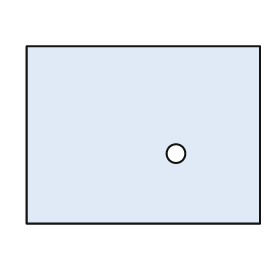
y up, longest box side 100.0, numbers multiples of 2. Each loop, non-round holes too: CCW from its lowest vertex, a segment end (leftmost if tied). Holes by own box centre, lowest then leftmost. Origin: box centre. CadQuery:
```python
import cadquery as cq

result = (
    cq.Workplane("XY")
    .moveTo(-50.0, -38.0)
    .lineTo(50.0, -38.0)
    .lineTo(50.0, 38.0)
    .lineTo(-50.0, 38.0)
    .close()
    .moveTo(14.0, -8.0)
    .circle(4.0)
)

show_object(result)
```